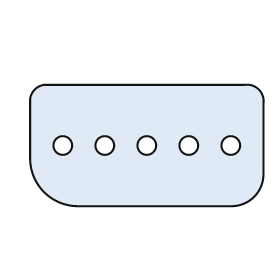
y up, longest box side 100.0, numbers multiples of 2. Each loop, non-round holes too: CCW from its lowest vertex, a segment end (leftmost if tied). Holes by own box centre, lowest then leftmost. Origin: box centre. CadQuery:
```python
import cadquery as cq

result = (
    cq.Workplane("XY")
    .moveTo(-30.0, -26.0)
    .lineTo(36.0, -26.0)
    .threePointArc((46.0, -22.0), (50.0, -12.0))
    .lineTo(50.0, 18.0)
    .threePointArc((48.0, 24.0), (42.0, 26.0))
    .lineTo(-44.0, 26.0)
    .threePointArc((-48.0, 24.0), (-50.0, 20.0))
    .lineTo(-50.0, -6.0)
    .threePointArc((-44.0, -20.0), (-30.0, -26.0))
    .close()
    .moveTo(-36.0, 0.0)
    .circle(4.0)
    .moveTo(-18.0, 0.0)
    .circle(4.0)
    .moveTo(0.0, 0.0)
    .circle(4.0)
    .moveTo(18.0, 0.0)
    .circle(4.0)
    .moveTo(36.0, 0.0)
    .circle(4.0)
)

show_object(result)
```